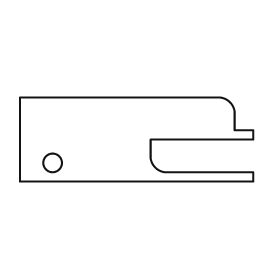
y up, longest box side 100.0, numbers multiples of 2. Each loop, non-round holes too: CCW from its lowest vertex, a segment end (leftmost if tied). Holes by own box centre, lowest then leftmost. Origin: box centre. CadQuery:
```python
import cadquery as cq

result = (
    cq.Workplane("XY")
    .moveTo(-50.0, -18.0)
    .lineTo(50.0, -18.0)
    .lineTo(50.0, -14.0)
    .lineTo(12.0, -14.0)
    .threePointArc((8.0, -12.0), (6.0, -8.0))
    .lineTo(6.0, 0.0)
    .lineTo(50.0, 0.0)
    .lineTo(50.0, 4.0)
    .lineTo(42.0, 4.0)
    .lineTo(42.0, 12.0)
    .threePointArc((40.0, 16.0), (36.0, 18.0))
    .lineTo(-50.0, 18.0)
    .close()
    .moveTo(-36.0, -10.0)
    .circle(4.0)
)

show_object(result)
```